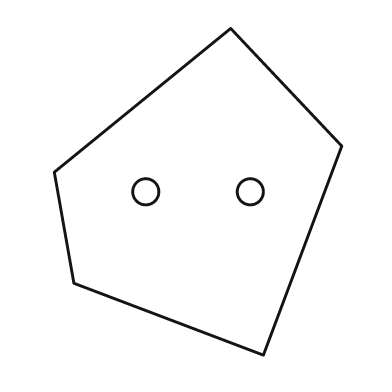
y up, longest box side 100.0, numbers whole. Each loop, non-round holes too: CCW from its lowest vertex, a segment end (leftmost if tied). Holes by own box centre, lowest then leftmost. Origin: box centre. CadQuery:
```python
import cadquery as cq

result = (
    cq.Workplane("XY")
    .moveTo(20.0, -50.0)
    .lineTo(44.0, 14.0)
    .lineTo(10.0, 50.0)
    .lineTo(-44.0, 6.0)
    .lineTo(-38.0, -28.0)
    .close()
    .moveTo(-16.0, 0.0)
    .circle(4.0)
    .moveTo(16.0, 0.0)
    .circle(4.0)
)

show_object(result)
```